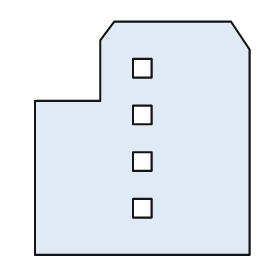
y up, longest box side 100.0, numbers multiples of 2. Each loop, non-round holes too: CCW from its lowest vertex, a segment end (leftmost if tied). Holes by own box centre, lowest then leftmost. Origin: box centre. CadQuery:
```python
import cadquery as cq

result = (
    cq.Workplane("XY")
    .moveTo(-46.0, -50.0)
    .lineTo(46.0, -50.0)
    .lineTo(46.0, 38.0)
    .lineTo(38.0, 50.0)
    .lineTo(-12.0, 50.0)
    .lineTo(-18.0, 42.0)
    .lineTo(-18.0, 16.0)
    .lineTo(-46.0, 16.0)
    .close()
    .moveTo(-4.0, -34.0)
    .lineTo(4.0, -34.0)
    .lineTo(4.0, -26.0)
    .lineTo(-4.0, -26.0)
    .close()
    .moveTo(-4.0, -14.0)
    .lineTo(4.0, -14.0)
    .lineTo(4.0, -6.0)
    .lineTo(-4.0, -6.0)
    .close()
    .moveTo(-4.0, 6.0)
    .lineTo(4.0, 6.0)
    .lineTo(4.0, 14.0)
    .lineTo(-4.0, 14.0)
    .close()
    .moveTo(-4.0, 26.0)
    .lineTo(4.0, 26.0)
    .lineTo(4.0, 34.0)
    .lineTo(-4.0, 34.0)
    .close()
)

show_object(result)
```